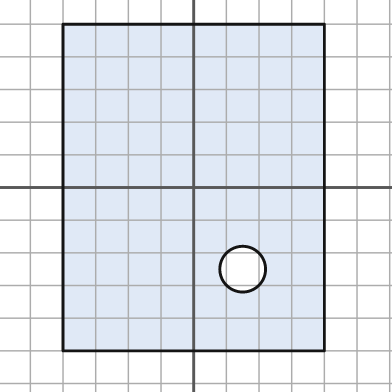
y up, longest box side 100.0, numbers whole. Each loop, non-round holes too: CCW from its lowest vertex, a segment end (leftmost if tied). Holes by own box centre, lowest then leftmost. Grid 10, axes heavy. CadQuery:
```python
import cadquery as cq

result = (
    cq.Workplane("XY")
    .moveTo(-40.0, -50.0)
    .lineTo(40.0, -50.0)
    .lineTo(40.0, 50.0)
    .lineTo(-40.0, 50.0)
    .close()
    .moveTo(15.0, -25.0)
    .circle(7.0)
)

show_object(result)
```